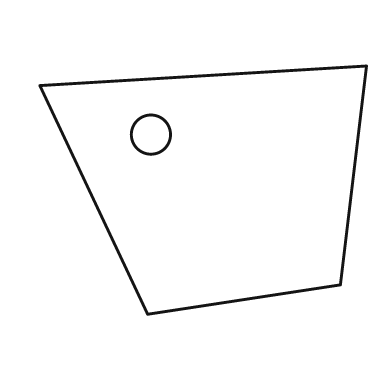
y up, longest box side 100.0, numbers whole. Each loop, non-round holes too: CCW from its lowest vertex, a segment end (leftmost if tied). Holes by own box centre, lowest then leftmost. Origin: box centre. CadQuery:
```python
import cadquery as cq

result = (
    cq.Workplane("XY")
    .moveTo(-17.0, -38.0)
    .lineTo(42.0, -29.0)
    .lineTo(50.0, 38.0)
    .lineTo(-50.0, 32.0)
    .close()
    .moveTo(-16.0, 17.0)
    .circle(6.0)
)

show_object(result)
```